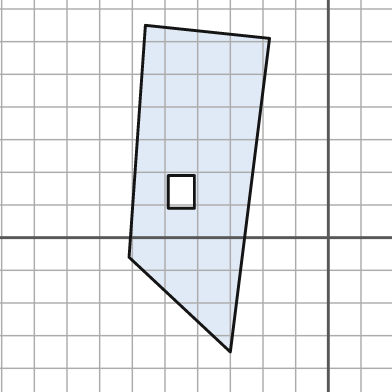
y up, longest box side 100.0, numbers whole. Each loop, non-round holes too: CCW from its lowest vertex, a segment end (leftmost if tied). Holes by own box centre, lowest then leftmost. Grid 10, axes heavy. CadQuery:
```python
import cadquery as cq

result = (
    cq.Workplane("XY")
    .moveTo(-30.0, -35.0)
    .lineTo(-18.0, 61.0)
    .lineTo(-56.0, 65.0)
    .lineTo(-61.0, -6.0)
    .close()
    .moveTo(-49.0, 9.0)
    .lineTo(-41.0, 9.0)
    .lineTo(-41.0, 19.0)
    .lineTo(-49.0, 19.0)
    .close()
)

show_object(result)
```